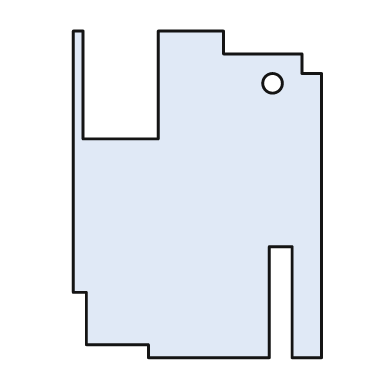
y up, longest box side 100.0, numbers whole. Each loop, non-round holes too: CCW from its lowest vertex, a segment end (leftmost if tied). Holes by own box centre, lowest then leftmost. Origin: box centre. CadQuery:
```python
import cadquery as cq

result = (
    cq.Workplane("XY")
    .moveTo(-15.0, -50.0)
    .lineTo(22.0, -50.0)
    .lineTo(22.0, -16.0)
    .lineTo(29.0, -16.0)
    .lineTo(29.0, -50.0)
    .lineTo(38.0, -50.0)
    .lineTo(38.0, 37.0)
    .lineTo(32.0, 37.0)
    .lineTo(32.0, 43.0)
    .lineTo(8.0, 43.0)
    .lineTo(8.0, 50.0)
    .lineTo(-12.0, 50.0)
    .lineTo(-12.0, 17.0)
    .lineTo(-35.0, 17.0)
    .lineTo(-35.0, 50.0)
    .lineTo(-38.0, 50.0)
    .lineTo(-38.0, -30.0)
    .lineTo(-34.0, -30.0)
    .lineTo(-34.0, -46.0)
    .lineTo(-15.0, -46.0)
    .close()
    .moveTo(23.0, 34.0)
    .circle(3.0)
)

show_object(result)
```